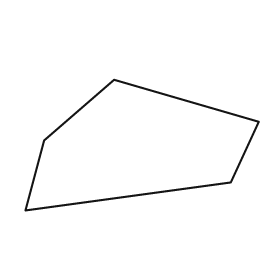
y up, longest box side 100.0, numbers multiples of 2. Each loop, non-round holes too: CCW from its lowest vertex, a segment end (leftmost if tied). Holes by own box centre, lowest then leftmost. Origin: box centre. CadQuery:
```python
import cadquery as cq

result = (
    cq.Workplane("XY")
    .moveTo(-50.0, -28.0)
    .lineTo(38.0, -16.0)
    .lineTo(50.0, 10.0)
    .lineTo(-12.0, 28.0)
    .lineTo(-42.0, 2.0)
    .close()
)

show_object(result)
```